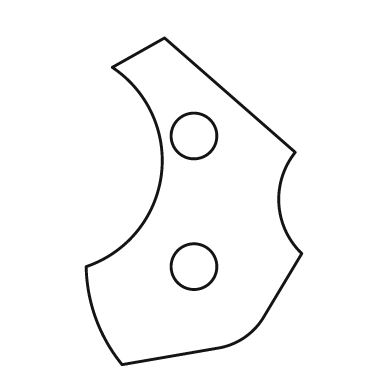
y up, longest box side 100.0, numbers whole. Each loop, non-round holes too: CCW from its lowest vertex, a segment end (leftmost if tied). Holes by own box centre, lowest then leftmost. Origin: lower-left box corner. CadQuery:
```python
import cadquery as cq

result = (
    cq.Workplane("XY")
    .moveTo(11.0, 0.0)
    .lineTo(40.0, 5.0)
    .threePointArc((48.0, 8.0), (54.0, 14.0))
    .lineTo(66.0, 34.0)
    .threePointArc((59.0, 49.0), (64.0, 65.0))
    .lineTo(24.0, 100.0)
    .lineTo(8.0, 91.0)
    .threePointArc((23.0, 58.0), (0.0, 30.0))
    .threePointArc((3.0, 14.0), (11.0, 0.0))
    .close()
    .moveTo(33.0, 30.0)
    .circle(7.0)
    .moveTo(33.0, 70.0)
    .circle(7.0)
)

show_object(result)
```